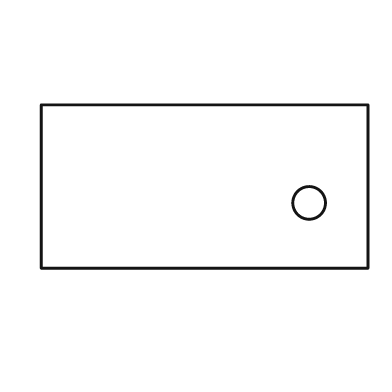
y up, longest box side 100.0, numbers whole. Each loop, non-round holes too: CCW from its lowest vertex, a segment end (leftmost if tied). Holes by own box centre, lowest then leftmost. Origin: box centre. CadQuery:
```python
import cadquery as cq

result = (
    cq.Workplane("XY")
    .moveTo(-50.0, -25.0)
    .lineTo(50.0, -25.0)
    .lineTo(50.0, 25.0)
    .lineTo(-50.0, 25.0)
    .close()
    .moveTo(32.0, -5.0)
    .circle(5.0)
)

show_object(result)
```